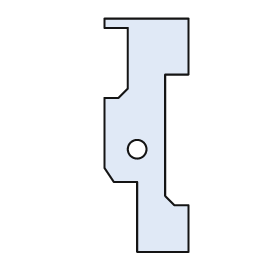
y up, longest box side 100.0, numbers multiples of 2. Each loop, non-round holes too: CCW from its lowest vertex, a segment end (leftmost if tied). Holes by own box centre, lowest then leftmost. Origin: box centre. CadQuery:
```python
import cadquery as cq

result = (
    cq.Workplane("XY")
    .moveTo(-4.0, -50.0)
    .lineTo(18.0, -50.0)
    .lineTo(18.0, -30.0)
    .lineTo(12.0, -30.0)
    .lineTo(8.0, -26.0)
    .lineTo(8.0, 26.0)
    .lineTo(18.0, 26.0)
    .lineTo(18.0, 50.0)
    .lineTo(-18.0, 50.0)
    .lineTo(-18.0, 46.0)
    .lineTo(-8.0, 46.0)
    .lineTo(-8.0, 20.0)
    .lineTo(-12.0, 16.0)
    .lineTo(-18.0, 16.0)
    .lineTo(-18.0, -14.0)
    .lineTo(-14.0, -20.0)
    .lineTo(-4.0, -20.0)
    .close()
    .moveTo(-4.0, -6.0)
    .circle(4.0)
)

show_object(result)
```